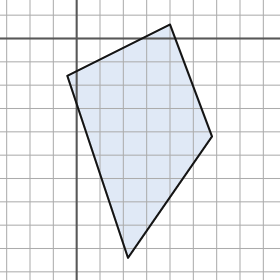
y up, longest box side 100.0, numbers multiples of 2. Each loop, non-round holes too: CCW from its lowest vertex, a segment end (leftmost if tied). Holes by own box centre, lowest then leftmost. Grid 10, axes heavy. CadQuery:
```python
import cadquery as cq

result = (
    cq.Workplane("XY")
    .moveTo(22.0, -94.0)
    .lineTo(58.0, -42.0)
    .lineTo(40.0, 6.0)
    .lineTo(-4.0, -16.0)
    .close()
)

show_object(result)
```